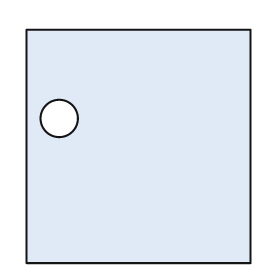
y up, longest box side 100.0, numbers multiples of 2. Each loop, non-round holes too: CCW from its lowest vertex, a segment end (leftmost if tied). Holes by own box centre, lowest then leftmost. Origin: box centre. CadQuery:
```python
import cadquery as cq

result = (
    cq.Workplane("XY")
    .moveTo(-48.0, -50.0)
    .lineTo(48.0, -50.0)
    .lineTo(48.0, 50.0)
    .lineTo(-48.0, 50.0)
    .close()
    .moveTo(-34.0, 12.0)
    .circle(8.0)
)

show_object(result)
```